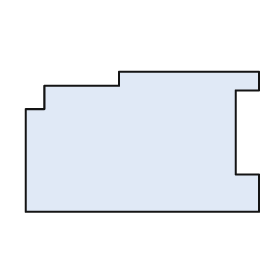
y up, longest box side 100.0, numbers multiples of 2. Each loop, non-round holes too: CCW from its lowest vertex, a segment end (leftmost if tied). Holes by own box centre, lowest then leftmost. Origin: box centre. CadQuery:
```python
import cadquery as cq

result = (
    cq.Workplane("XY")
    .moveTo(-50.0, -30.0)
    .lineTo(50.0, -30.0)
    .lineTo(50.0, -14.0)
    .lineTo(40.0, -14.0)
    .lineTo(40.0, 22.0)
    .lineTo(50.0, 22.0)
    .lineTo(50.0, 30.0)
    .lineTo(-10.0, 30.0)
    .lineTo(-10.0, 24.0)
    .lineTo(-42.0, 24.0)
    .lineTo(-42.0, 14.0)
    .lineTo(-50.0, 14.0)
    .close()
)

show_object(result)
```